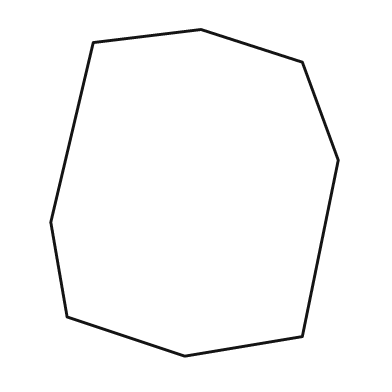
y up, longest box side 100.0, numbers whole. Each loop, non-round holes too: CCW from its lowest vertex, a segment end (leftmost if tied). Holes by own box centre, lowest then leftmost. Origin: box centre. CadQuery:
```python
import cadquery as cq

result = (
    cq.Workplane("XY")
    .moveTo(-3.0, -50.0)
    .lineTo(33.0, -44.0)
    .lineTo(44.0, 10.0)
    .lineTo(33.0, 40.0)
    .lineTo(2.0, 50.0)
    .lineTo(-31.0, 46.0)
    .lineTo(-44.0, -9.0)
    .lineTo(-39.0, -38.0)
    .close()
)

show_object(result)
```